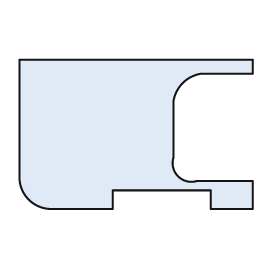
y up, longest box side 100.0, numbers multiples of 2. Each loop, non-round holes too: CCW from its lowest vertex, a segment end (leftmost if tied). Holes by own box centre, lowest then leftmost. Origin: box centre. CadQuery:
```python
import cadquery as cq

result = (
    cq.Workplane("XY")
    .moveTo(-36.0, -32.0)
    .lineTo(-10.0, -32.0)
    .lineTo(-10.0, -24.0)
    .lineTo(32.0, -24.0)
    .lineTo(32.0, -32.0)
    .lineTo(50.0, -32.0)
    .lineTo(50.0, -20.0)
    .lineTo(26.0, -20.0)
    .threePointArc((18.0, -18.0), (16.0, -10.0))
    .lineTo(16.0, 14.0)
    .threePointArc((20.0, 22.0), (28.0, 26.0))
    .lineTo(50.0, 26.0)
    .lineTo(50.0, 32.0)
    .lineTo(-50.0, 32.0)
    .lineTo(-50.0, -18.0)
    .threePointArc((-46.0, -28.0), (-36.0, -32.0))
    .close()
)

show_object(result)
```